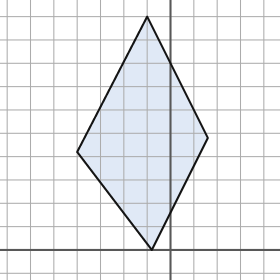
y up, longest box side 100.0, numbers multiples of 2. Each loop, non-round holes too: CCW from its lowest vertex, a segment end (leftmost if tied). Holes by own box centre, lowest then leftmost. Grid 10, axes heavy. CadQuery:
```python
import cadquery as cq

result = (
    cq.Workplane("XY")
    .moveTo(-8.0, 0.0)
    .lineTo(16.0, 48.0)
    .lineTo(-10.0, 100.0)
    .lineTo(-40.0, 42.0)
    .close()
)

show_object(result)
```